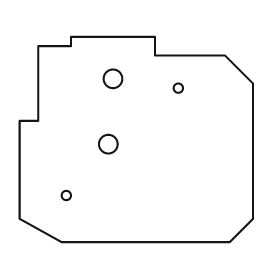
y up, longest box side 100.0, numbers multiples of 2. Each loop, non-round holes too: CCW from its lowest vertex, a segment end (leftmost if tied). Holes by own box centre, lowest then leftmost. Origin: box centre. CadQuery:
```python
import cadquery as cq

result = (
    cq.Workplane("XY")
    .moveTo(-32.0, -44.0)
    .lineTo(40.0, -44.0)
    .lineTo(50.0, -34.0)
    .lineTo(50.0, 24.0)
    .lineTo(38.0, 36.0)
    .lineTo(8.0, 36.0)
    .lineTo(8.0, 44.0)
    .lineTo(-28.0, 44.0)
    .lineTo(-28.0, 40.0)
    .lineTo(-42.0, 40.0)
    .lineTo(-42.0, 8.0)
    .lineTo(-50.0, 8.0)
    .lineTo(-50.0, -34.0)
    .close()
    .moveTo(-30.0, -24.0)
    .circle(2.0)
    .moveTo(-12.0, -2.0)
    .circle(4.0)
    .moveTo(18.0, 22.0)
    .circle(2.0)
    .moveTo(-10.0, 26.0)
    .circle(4.0)
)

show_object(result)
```